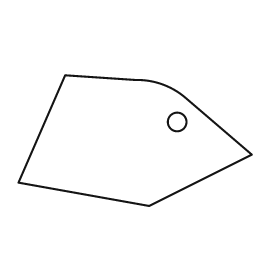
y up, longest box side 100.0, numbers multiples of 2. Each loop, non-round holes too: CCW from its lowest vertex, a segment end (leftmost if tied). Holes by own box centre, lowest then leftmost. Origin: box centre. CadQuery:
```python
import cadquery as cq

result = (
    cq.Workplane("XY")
    .moveTo(6.0, -28.0)
    .lineTo(50.0, -6.0)
    .lineTo(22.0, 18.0)
    .threePointArc((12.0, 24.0), (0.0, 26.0))
    .lineTo(-30.0, 28.0)
    .lineTo(-50.0, -18.0)
    .close()
    .moveTo(18.0, 8.0)
    .circle(4.0)
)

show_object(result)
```